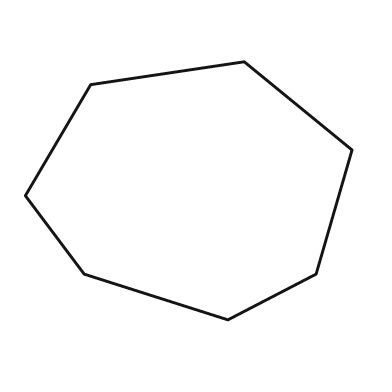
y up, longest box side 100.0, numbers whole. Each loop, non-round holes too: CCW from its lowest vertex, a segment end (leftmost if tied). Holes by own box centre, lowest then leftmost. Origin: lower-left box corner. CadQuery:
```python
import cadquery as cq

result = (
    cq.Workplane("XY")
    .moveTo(62.0, 0.0)
    .lineTo(89.0, 14.0)
    .lineTo(100.0, 52.0)
    .lineTo(67.0, 79.0)
    .lineTo(20.0, 72.0)
    .lineTo(0.0, 38.0)
    .lineTo(18.0, 14.0)
    .close()
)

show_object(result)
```